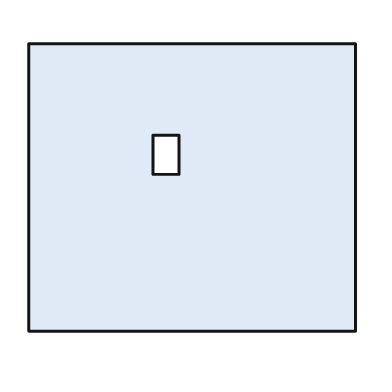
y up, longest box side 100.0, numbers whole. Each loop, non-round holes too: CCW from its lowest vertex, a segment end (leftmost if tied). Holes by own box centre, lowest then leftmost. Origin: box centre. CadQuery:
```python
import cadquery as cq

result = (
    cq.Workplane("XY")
    .moveTo(-50.0, -44.0)
    .lineTo(50.0, -44.0)
    .lineTo(50.0, 44.0)
    .lineTo(-50.0, 44.0)
    .close()
    .moveTo(-12.0, 4.0)
    .lineTo(-4.0, 4.0)
    .lineTo(-4.0, 16.0)
    .lineTo(-12.0, 16.0)
    .close()
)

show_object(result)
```